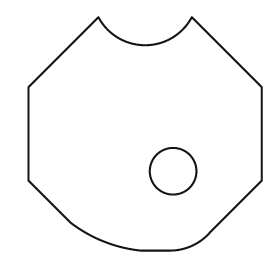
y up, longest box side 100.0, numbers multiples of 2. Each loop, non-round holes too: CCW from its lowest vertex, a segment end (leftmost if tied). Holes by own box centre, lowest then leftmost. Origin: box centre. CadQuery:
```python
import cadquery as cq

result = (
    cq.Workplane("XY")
    .moveTo(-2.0, -50.0)
    .lineTo(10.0, -50.0)
    .threePointArc((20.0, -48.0), (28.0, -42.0))
    .lineTo(50.0, -20.0)
    .lineTo(50.0, 20.0)
    .lineTo(20.0, 50.0)
    .threePointArc((0.0, 38.0), (-20.0, 50.0))
    .lineTo(-50.0, 20.0)
    .lineTo(-50.0, -20.0)
    .lineTo(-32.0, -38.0)
    .threePointArc((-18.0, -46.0), (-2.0, -50.0))
    .close()
    .moveTo(12.0, -16.0)
    .circle(10.0)
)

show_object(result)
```